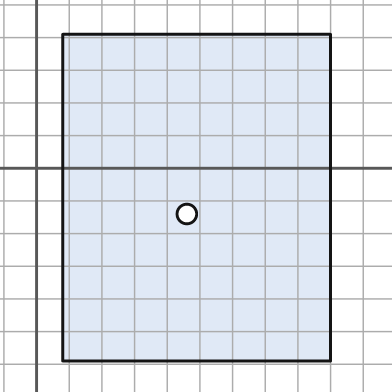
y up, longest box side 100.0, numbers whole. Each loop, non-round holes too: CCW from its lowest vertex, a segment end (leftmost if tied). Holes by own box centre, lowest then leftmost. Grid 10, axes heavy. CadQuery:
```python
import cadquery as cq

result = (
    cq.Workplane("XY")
    .moveTo(8.0, -59.0)
    .lineTo(90.0, -59.0)
    .lineTo(90.0, 41.0)
    .lineTo(8.0, 41.0)
    .close()
    .moveTo(46.0, -14.0)
    .circle(3.0)
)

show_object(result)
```